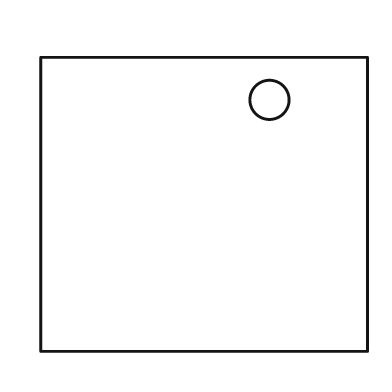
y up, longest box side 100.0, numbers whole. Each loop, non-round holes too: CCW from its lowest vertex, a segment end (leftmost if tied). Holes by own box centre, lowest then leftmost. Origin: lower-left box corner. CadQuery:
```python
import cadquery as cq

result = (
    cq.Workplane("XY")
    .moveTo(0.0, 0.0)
    .lineTo(100.0, 0.0)
    .lineTo(100.0, 90.0)
    .lineTo(0.0, 90.0)
    .close()
    .moveTo(70.0, 77.0)
    .circle(6.0)
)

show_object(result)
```